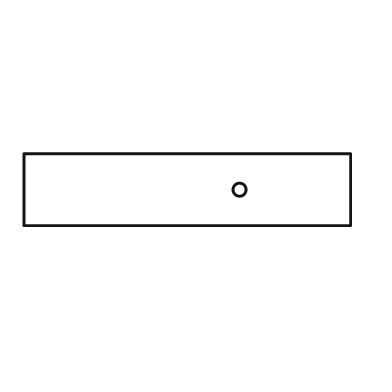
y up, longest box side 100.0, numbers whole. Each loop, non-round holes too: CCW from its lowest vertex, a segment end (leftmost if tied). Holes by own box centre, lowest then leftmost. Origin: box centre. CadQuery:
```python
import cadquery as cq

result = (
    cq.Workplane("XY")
    .moveTo(-50.0, -11.0)
    .lineTo(50.0, -11.0)
    .lineTo(50.0, 11.0)
    .lineTo(-50.0, 11.0)
    .close()
    .moveTo(16.0, 0.0)
    .circle(2.0)
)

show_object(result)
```